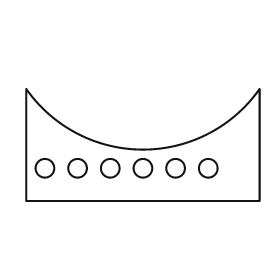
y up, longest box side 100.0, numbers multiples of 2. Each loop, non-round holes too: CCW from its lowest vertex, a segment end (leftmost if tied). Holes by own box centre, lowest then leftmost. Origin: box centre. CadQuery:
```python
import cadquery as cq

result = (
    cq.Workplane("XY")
    .moveTo(-50.0, -24.0)
    .lineTo(50.0, -24.0)
    .lineTo(50.0, 24.0)
    .threePointArc((0.0, -2.0), (-50.0, 24.0))
    .close()
    .moveTo(-42.0, -10.0)
    .circle(4.0)
    .moveTo(-28.0, -10.0)
    .circle(4.0)
    .moveTo(-14.0, -10.0)
    .circle(4.0)
    .moveTo(0.0, -10.0)
    .circle(4.0)
    .moveTo(14.0, -10.0)
    .circle(4.0)
    .moveTo(28.0, -10.0)
    .circle(4.0)
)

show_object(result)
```